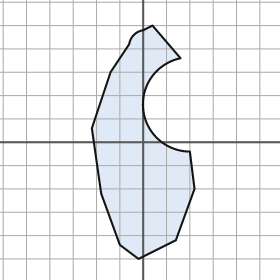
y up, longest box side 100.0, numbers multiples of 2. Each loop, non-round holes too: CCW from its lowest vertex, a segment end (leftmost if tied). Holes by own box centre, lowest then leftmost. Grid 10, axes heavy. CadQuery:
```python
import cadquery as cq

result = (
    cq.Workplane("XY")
    .moveTo(-2.0, -50.0)
    .lineTo(14.0, -42.0)
    .lineTo(22.0, -20.0)
    .lineTo(20.0, -4.0)
    .threePointArc((0.0, 14.0), (16.0, 36.0))
    .lineTo(4.0, 50.0)
    .lineTo(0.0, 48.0)
    .threePointArc((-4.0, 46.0), (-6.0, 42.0))
    .lineTo(-14.0, 30.0)
    .lineTo(-22.0, 6.0)
    .lineTo(-18.0, -22.0)
    .lineTo(-10.0, -44.0)
    .close()
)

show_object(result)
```